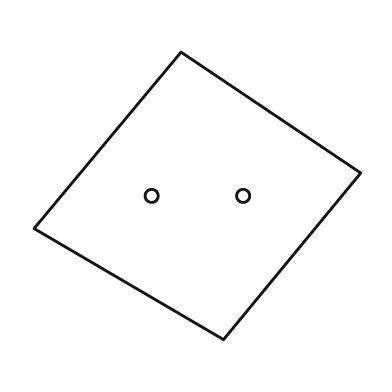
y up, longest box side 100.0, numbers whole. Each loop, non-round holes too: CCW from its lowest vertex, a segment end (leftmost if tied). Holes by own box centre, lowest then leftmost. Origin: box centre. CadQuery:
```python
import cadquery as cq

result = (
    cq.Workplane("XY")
    .moveTo(8.0, -44.0)
    .lineTo(50.0, 7.0)
    .lineTo(-5.0, 44.0)
    .lineTo(-50.0, -10.0)
    .close()
    .moveTo(-14.0, 0.0)
    .circle(2.0)
    .moveTo(14.0, 0.0)
    .circle(2.0)
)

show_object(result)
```